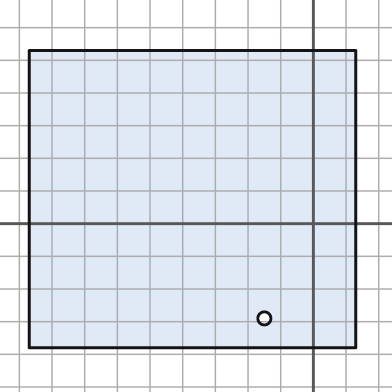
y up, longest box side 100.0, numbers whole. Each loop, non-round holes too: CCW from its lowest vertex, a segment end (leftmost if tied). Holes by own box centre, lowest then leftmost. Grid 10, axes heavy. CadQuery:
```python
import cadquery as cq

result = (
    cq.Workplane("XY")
    .moveTo(-87.0, -38.0)
    .lineTo(13.0, -38.0)
    .lineTo(13.0, 53.0)
    .lineTo(-87.0, 53.0)
    .close()
    .moveTo(-15.0, -29.0)
    .circle(2.0)
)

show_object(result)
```